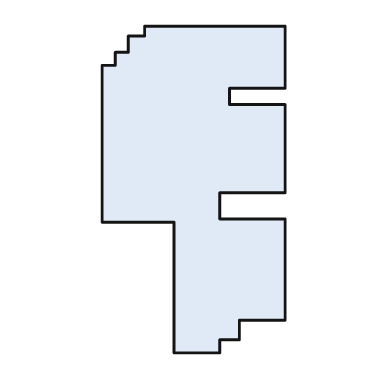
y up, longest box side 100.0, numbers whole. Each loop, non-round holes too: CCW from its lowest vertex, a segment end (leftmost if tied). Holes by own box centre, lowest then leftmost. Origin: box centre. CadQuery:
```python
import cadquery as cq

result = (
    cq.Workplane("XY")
    .moveTo(-6.0, -50.0)
    .lineTo(8.0, -50.0)
    .lineTo(8.0, -46.0)
    .lineTo(14.0, -46.0)
    .lineTo(14.0, -40.0)
    .lineTo(28.0, -40.0)
    .lineTo(28.0, -9.0)
    .lineTo(8.0, -9.0)
    .lineTo(8.0, -1.0)
    .lineTo(28.0, -1.0)
    .lineTo(28.0, 26.0)
    .lineTo(11.0, 26.0)
    .lineTo(11.0, 31.0)
    .lineTo(28.0, 31.0)
    .lineTo(28.0, 50.0)
    .lineTo(-15.0, 50.0)
    .lineTo(-15.0, 47.0)
    .lineTo(-20.0, 47.0)
    .lineTo(-20.0, 42.0)
    .lineTo(-24.0, 42.0)
    .lineTo(-24.0, 38.0)
    .lineTo(-28.0, 38.0)
    .lineTo(-28.0, -10.0)
    .lineTo(-6.0, -10.0)
    .close()
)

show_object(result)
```